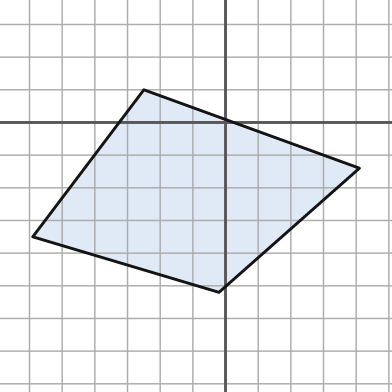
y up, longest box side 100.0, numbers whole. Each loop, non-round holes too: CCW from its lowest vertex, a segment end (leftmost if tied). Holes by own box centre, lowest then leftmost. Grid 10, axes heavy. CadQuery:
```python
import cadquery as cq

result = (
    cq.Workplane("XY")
    .moveTo(-2.0, -52.0)
    .lineTo(41.0, -14.0)
    .lineTo(-25.0, 10.0)
    .lineTo(-59.0, -35.0)
    .close()
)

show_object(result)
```